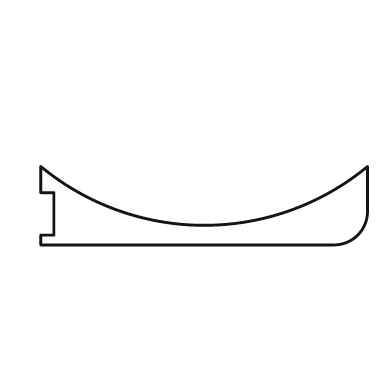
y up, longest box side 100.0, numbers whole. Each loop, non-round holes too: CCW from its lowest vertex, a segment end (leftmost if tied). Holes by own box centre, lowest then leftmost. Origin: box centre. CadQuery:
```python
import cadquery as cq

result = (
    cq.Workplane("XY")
    .moveTo(-50.0, -12.0)
    .lineTo(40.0, -12.0)
    .threePointArc((47.0, -9.0), (50.0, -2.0))
    .lineTo(50.0, 12.0)
    .threePointArc((0.0, -6.0), (-50.0, 12.0))
    .lineTo(-50.0, 4.0)
    .lineTo(-46.0, 4.0)
    .lineTo(-46.0, -9.0)
    .lineTo(-50.0, -9.0)
    .close()
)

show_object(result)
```